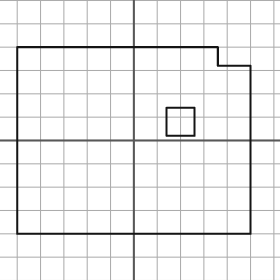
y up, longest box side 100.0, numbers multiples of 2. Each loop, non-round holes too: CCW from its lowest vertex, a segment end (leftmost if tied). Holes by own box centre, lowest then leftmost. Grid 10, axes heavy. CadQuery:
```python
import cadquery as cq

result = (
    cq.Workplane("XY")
    .moveTo(-50.0, -40.0)
    .lineTo(50.0, -40.0)
    .lineTo(50.0, 32.0)
    .lineTo(36.0, 32.0)
    .lineTo(36.0, 40.0)
    .lineTo(-50.0, 40.0)
    .close()
    .moveTo(14.0, 2.0)
    .lineTo(26.0, 2.0)
    .lineTo(26.0, 14.0)
    .lineTo(14.0, 14.0)
    .close()
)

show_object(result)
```